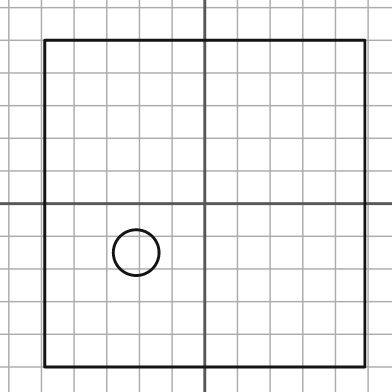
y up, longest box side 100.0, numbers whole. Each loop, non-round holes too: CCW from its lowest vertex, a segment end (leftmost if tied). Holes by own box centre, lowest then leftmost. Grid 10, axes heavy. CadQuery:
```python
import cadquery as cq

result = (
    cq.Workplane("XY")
    .moveTo(-49.0, -50.0)
    .lineTo(49.0, -50.0)
    .lineTo(49.0, 50.0)
    .lineTo(-49.0, 50.0)
    .close()
    .moveTo(-21.0, -15.0)
    .circle(7.0)
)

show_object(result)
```